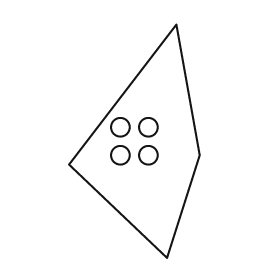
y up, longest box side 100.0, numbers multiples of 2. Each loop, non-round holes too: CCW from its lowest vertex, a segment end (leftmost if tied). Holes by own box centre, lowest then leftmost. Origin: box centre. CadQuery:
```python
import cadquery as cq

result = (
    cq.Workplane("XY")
    .moveTo(14.0, -50.0)
    .lineTo(28.0, -6.0)
    .lineTo(18.0, 50.0)
    .lineTo(-28.0, -10.0)
    .close()
    .moveTo(-6.0, -6.0)
    .circle(4.0)
    .moveTo(6.0, -6.0)
    .circle(4.0)
    .moveTo(-6.0, 6.0)
    .circle(4.0)
    .moveTo(6.0, 6.0)
    .circle(4.0)
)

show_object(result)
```